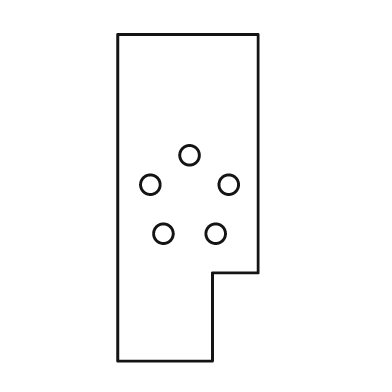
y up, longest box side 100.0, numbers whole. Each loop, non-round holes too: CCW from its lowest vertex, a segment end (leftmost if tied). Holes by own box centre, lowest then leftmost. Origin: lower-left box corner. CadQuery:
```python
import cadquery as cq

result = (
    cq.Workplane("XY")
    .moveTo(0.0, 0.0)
    .lineTo(29.0, 0.0)
    .lineTo(29.0, 27.0)
    .lineTo(43.0, 27.0)
    .lineTo(43.0, 100.0)
    .lineTo(0.0, 100.0)
    .close()
    .moveTo(14.0, 39.0)
    .circle(3.0)
    .moveTo(30.0, 39.0)
    .circle(3.0)
    .moveTo(10.0, 54.0)
    .circle(3.0)
    .moveTo(34.0, 54.0)
    .circle(3.0)
    .moveTo(22.0, 63.0)
    .circle(3.0)
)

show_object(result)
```